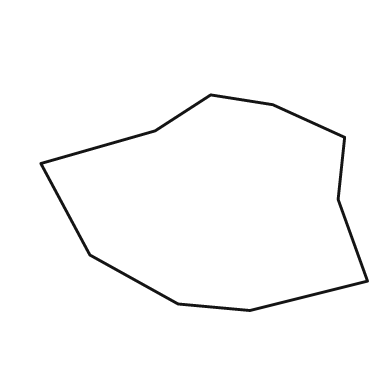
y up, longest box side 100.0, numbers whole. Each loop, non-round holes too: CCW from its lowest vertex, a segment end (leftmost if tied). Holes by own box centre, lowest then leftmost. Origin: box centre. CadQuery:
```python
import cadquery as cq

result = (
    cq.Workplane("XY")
    .moveTo(14.0, -33.0)
    .lineTo(50.0, -24.0)
    .lineTo(41.0, 1.0)
    .lineTo(43.0, 20.0)
    .lineTo(21.0, 30.0)
    .lineTo(2.0, 33.0)
    .lineTo(-15.0, 22.0)
    .lineTo(-50.0, 12.0)
    .lineTo(-35.0, -16.0)
    .lineTo(-8.0, -31.0)
    .close()
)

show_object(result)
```